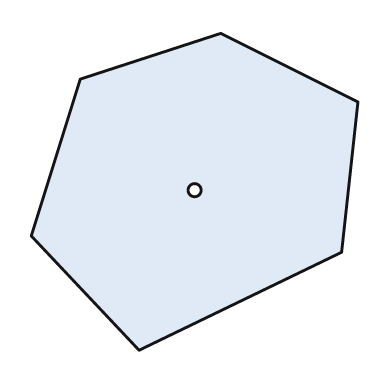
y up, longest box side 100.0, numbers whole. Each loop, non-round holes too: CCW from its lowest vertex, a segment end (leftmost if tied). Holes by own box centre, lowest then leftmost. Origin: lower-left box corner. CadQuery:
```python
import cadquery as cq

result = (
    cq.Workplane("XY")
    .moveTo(33.0, 0.0)
    .lineTo(95.0, 30.0)
    .lineTo(100.0, 76.0)
    .lineTo(58.0, 97.0)
    .lineTo(15.0, 83.0)
    .lineTo(0.0, 35.0)
    .close()
    .moveTo(50.0, 49.0)
    .circle(2.0)
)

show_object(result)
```